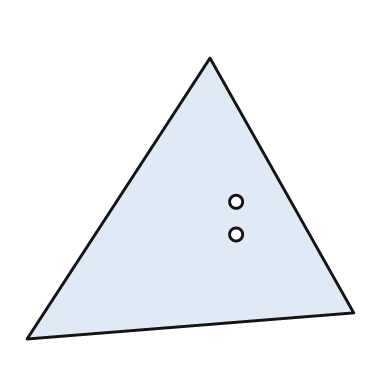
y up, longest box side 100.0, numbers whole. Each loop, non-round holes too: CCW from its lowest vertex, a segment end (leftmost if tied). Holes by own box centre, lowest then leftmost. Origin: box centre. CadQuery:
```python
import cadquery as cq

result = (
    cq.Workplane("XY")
    .moveTo(-50.0, -43.0)
    .lineTo(50.0, -35.0)
    .lineTo(6.0, 43.0)
    .close()
    .moveTo(14.0, -11.0)
    .circle(2.0)
    .moveTo(14.0, -1.0)
    .circle(2.0)
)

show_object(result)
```